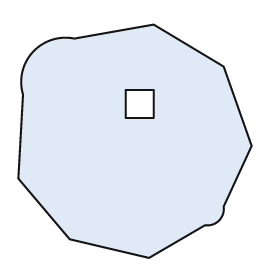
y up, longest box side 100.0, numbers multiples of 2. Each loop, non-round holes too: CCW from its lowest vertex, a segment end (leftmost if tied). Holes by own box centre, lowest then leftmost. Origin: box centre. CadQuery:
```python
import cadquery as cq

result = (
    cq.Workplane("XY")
    .moveTo(6.0, -50.0)
    .lineTo(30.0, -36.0)
    .threePointArc((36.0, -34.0), (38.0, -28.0))
    .lineTo(50.0, -2.0)
    .lineTo(38.0, 32.0)
    .lineTo(8.0, 50.0)
    .lineTo(-26.0, 44.0)
    .threePointArc((-44.0, 38.0), (-48.0, 20.0))
    .lineTo(-50.0, -16.0)
    .lineTo(-28.0, -42.0)
    .close()
    .moveTo(-4.0, 10.0)
    .lineTo(8.0, 10.0)
    .lineTo(8.0, 22.0)
    .lineTo(-4.0, 22.0)
    .close()
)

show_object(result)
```